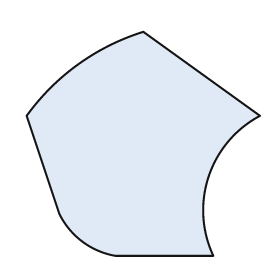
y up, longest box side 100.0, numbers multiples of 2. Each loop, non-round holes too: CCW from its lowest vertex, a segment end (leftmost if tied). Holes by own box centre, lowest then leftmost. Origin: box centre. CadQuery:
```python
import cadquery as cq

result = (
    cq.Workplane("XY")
    .moveTo(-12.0, -48.0)
    .lineTo(30.0, -48.0)
    .threePointArc((28.0, -14.0), (50.0, 12.0))
    .lineTo(0.0, 48.0)
    .threePointArc((-28.0, 34.0), (-50.0, 12.0))
    .lineTo(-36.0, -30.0)
    .threePointArc((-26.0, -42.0), (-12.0, -48.0))
    .close()
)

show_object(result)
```